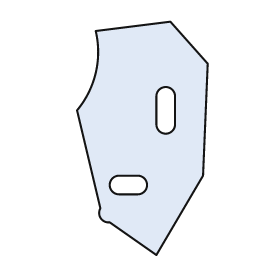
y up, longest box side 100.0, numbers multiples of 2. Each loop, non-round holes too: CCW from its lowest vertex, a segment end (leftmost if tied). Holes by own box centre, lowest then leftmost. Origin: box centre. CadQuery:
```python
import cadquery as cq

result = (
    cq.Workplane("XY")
    .moveTo(6.0, -50.0)
    .lineTo(26.0, -16.0)
    .lineTo(28.0, 32.0)
    .lineTo(12.0, 50.0)
    .lineTo(-20.0, 46.0)
    .threePointArc((-20.0, 28.0), (-28.0, 12.0))
    .lineTo(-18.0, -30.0)
    .threePointArc((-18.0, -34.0), (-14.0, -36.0))
    .close()
    .moveTo(-10.0, -24.0)
    .lineTo(-2.0, -24.0)
    .threePointArc((2.0, -20.0), (-2.0, -16.0))
    .lineTo(-10.0, -16.0)
    .threePointArc((-14.0, -20.0), (-10.0, -24.0))
    .close()
    .moveTo(6.0, 6.0)
    .threePointArc((10.0, 2.0), (14.0, 6.0))
    .lineTo(14.0, 18.0)
    .threePointArc((10.0, 22.0), (6.0, 18.0))
    .close()
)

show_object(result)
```